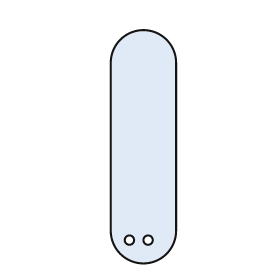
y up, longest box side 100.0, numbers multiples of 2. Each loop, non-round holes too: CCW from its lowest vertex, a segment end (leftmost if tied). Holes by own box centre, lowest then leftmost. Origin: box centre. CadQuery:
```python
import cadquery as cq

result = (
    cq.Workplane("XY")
    .moveTo(-14.0, -36.0)
    .threePointArc((0.0, -50.0), (14.0, -36.0))
    .lineTo(14.0, 36.0)
    .threePointArc((0.0, 50.0), (-14.0, 36.0))
    .close()
    .moveTo(-6.0, -40.0)
    .circle(2.0)
    .moveTo(2.0, -40.0)
    .circle(2.0)
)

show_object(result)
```